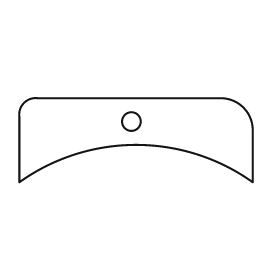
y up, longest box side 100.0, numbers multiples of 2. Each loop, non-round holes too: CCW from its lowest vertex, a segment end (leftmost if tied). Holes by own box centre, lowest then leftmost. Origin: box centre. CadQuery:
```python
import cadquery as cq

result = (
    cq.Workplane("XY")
    .moveTo(-50.0, -18.0)
    .threePointArc((0.0, -2.0), (50.0, -18.0))
    .lineTo(50.0, 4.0)
    .threePointArc((46.0, 14.0), (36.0, 18.0))
    .lineTo(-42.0, 18.0)
    .threePointArc((-48.0, 16.0), (-50.0, 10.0))
    .close()
    .moveTo(-2.0, 8.0)
    .circle(4.0)
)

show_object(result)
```